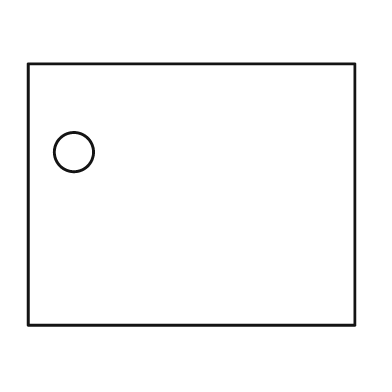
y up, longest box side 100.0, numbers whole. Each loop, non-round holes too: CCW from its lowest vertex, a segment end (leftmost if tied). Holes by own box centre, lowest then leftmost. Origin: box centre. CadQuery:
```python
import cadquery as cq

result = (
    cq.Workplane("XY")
    .moveTo(-50.0, -40.0)
    .lineTo(50.0, -40.0)
    .lineTo(50.0, 40.0)
    .lineTo(-50.0, 40.0)
    .close()
    .moveTo(-36.0, 13.0)
    .circle(6.0)
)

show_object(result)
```